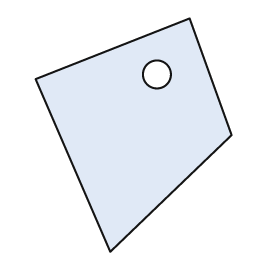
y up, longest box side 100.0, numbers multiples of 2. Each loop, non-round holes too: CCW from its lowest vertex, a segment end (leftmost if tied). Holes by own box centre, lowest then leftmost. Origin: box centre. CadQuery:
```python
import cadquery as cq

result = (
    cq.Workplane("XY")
    .moveTo(-10.0, -50.0)
    .lineTo(42.0, 0.0)
    .lineTo(24.0, 50.0)
    .lineTo(-42.0, 24.0)
    .close()
    .moveTo(10.0, 26.0)
    .circle(6.0)
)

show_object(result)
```